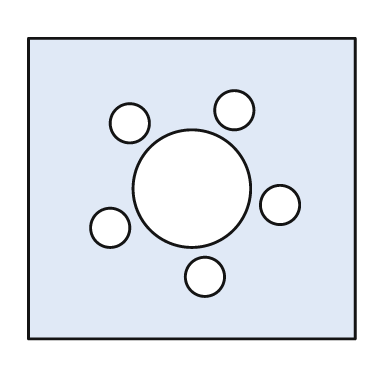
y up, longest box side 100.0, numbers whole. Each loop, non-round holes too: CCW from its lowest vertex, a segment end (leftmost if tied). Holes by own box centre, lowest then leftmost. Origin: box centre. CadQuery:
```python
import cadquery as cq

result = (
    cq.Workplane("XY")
    .moveTo(-50.0, -46.0)
    .lineTo(50.0, -46.0)
    .lineTo(50.0, 46.0)
    .lineTo(-50.0, 46.0)
    .close()
    .moveTo(4.0, -27.0)
    .circle(6.0)
    .moveTo(-25.0, -12.0)
    .circle(6.0)
    .moveTo(27.0, -5.0)
    .circle(6.0)
    .moveTo(0.0, 0.0)
    .circle(18.0)
    .moveTo(-19.0, 20.0)
    .circle(6.0)
    .moveTo(13.0, 24.0)
    .circle(6.0)
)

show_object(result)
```